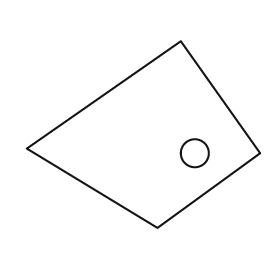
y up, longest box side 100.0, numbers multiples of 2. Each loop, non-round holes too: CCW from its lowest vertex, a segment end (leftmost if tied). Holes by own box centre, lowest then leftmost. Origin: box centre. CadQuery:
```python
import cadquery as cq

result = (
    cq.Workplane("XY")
    .moveTo(6.0, -40.0)
    .lineTo(50.0, -8.0)
    .lineTo(16.0, 40.0)
    .lineTo(-50.0, -6.0)
    .close()
    .moveTo(22.0, -8.0)
    .circle(6.0)
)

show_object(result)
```